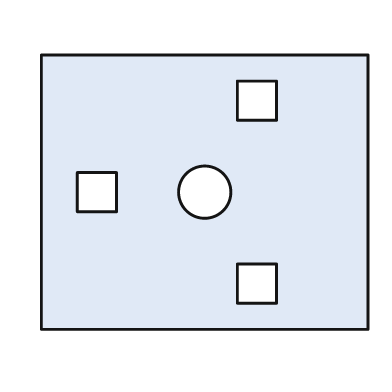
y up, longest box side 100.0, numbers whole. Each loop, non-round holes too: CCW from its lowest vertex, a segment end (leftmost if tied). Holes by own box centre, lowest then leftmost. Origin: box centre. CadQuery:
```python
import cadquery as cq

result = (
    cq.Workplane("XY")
    .moveTo(-50.0, -42.0)
    .lineTo(50.0, -42.0)
    .lineTo(50.0, 42.0)
    .lineTo(-50.0, 42.0)
    .close()
    .moveTo(10.0, -34.0)
    .lineTo(22.0, -34.0)
    .lineTo(22.0, -22.0)
    .lineTo(10.0, -22.0)
    .close()
    .moveTo(-39.0, -6.0)
    .lineTo(-27.0, -6.0)
    .lineTo(-27.0, 6.0)
    .lineTo(-39.0, 6.0)
    .close()
    .moveTo(0.0, 0.0)
    .circle(8.0)
    .moveTo(10.0, 22.0)
    .lineTo(22.0, 22.0)
    .lineTo(22.0, 34.0)
    .lineTo(10.0, 34.0)
    .close()
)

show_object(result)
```